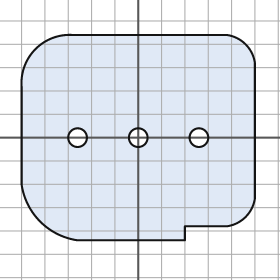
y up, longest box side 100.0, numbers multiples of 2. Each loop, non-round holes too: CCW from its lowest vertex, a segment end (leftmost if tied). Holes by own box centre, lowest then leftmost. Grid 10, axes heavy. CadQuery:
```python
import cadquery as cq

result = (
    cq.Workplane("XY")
    .moveTo(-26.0, -44.0)
    .lineTo(20.0, -44.0)
    .lineTo(20.0, -38.0)
    .lineTo(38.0, -38.0)
    .threePointArc((46.0, -34.0), (50.0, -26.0))
    .lineTo(50.0, 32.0)
    .threePointArc((46.0, 40.0), (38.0, 44.0))
    .lineTo(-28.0, 44.0)
    .threePointArc((-44.0, 38.0), (-50.0, 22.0))
    .lineTo(-50.0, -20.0)
    .threePointArc((-42.0, -36.0), (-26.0, -44.0))
    .close()
    .moveTo(-26.0, 0.0)
    .circle(4.0)
    .moveTo(0.0, 0.0)
    .circle(4.0)
    .moveTo(26.0, 0.0)
    .circle(4.0)
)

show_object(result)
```